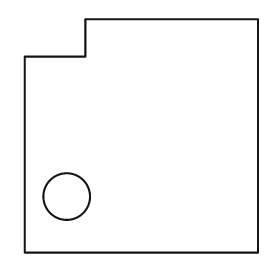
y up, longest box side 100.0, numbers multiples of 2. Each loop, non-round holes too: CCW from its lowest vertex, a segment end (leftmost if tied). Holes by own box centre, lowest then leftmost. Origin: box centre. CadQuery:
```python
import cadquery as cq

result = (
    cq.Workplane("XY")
    .moveTo(-50.0, -50.0)
    .lineTo(50.0, -50.0)
    .lineTo(50.0, 50.0)
    .lineTo(-24.0, 50.0)
    .lineTo(-24.0, 34.0)
    .lineTo(-50.0, 34.0)
    .close()
    .moveTo(-32.0, -26.0)
    .circle(10.0)
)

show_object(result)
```